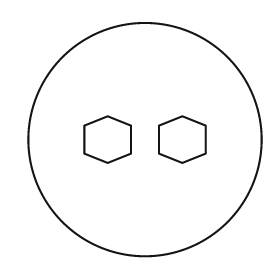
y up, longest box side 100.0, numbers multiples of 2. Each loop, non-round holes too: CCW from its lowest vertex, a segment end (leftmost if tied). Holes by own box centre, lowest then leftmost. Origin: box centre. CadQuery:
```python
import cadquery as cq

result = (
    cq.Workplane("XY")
    .moveTo(0.0, 0.0)
    .circle(50.0)
    .moveTo(-16.0, -10.0)
    .lineTo(-6.0, -6.0)
    .lineTo(-6.0, 6.0)
    .lineTo(-16.0, 10.0)
    .lineTo(-26.0, 6.0)
    .lineTo(-26.0, -6.0)
    .close()
    .moveTo(16.0, -10.0)
    .lineTo(26.0, -6.0)
    .lineTo(26.0, 6.0)
    .lineTo(16.0, 10.0)
    .lineTo(6.0, 6.0)
    .lineTo(6.0, -6.0)
    .close()
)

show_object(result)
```